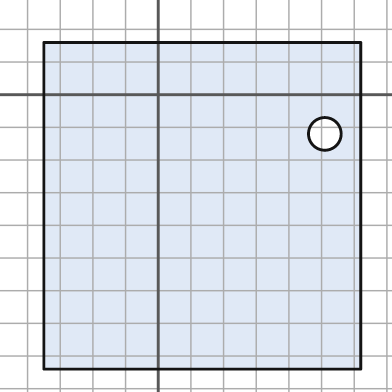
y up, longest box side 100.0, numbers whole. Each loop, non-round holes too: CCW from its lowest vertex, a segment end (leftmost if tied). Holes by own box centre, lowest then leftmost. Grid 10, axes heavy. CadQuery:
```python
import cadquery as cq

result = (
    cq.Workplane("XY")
    .moveTo(-35.0, -84.0)
    .lineTo(62.0, -84.0)
    .lineTo(62.0, 16.0)
    .lineTo(-35.0, 16.0)
    .close()
    .moveTo(51.0, -12.0)
    .circle(5.0)
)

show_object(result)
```